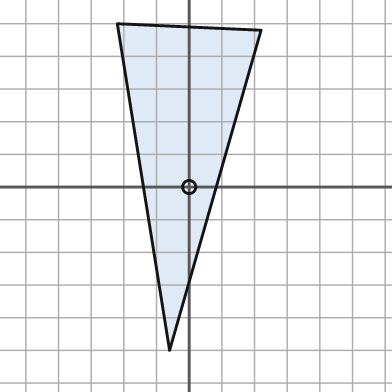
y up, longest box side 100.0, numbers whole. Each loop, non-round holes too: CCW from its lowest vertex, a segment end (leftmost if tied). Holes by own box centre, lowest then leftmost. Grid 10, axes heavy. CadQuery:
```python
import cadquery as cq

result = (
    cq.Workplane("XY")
    .moveTo(-6.0, -50.0)
    .lineTo(22.0, 48.0)
    .lineTo(-22.0, 50.0)
    .close()
    .moveTo(0.0, 0.0)
    .circle(2.0)
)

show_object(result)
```